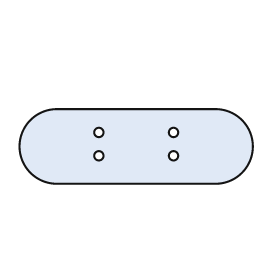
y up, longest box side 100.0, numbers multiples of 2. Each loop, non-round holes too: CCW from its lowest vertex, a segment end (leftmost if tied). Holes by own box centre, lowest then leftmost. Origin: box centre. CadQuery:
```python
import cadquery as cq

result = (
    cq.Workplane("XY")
    .moveTo(-34.0, -16.0)
    .lineTo(34.0, -16.0)
    .threePointArc((50.0, 0.0), (34.0, 16.0))
    .lineTo(-34.0, 16.0)
    .threePointArc((-50.0, 0.0), (-34.0, -16.0))
    .close()
    .moveTo(-16.0, -4.0)
    .circle(2.0)
    .moveTo(16.0, -4.0)
    .circle(2.0)
    .moveTo(-16.0, 6.0)
    .circle(2.0)
    .moveTo(16.0, 6.0)
    .circle(2.0)
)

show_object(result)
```